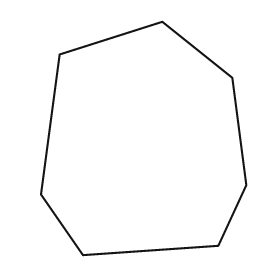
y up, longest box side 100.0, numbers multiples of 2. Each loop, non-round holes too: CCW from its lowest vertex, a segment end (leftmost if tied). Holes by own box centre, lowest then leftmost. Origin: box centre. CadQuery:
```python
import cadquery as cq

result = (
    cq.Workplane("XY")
    .moveTo(-26.0, -50.0)
    .lineTo(32.0, -46.0)
    .lineTo(44.0, -20.0)
    .lineTo(38.0, 26.0)
    .lineTo(8.0, 50.0)
    .lineTo(-36.0, 36.0)
    .lineTo(-44.0, -24.0)
    .close()
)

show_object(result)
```